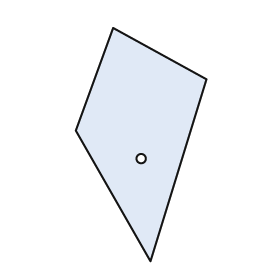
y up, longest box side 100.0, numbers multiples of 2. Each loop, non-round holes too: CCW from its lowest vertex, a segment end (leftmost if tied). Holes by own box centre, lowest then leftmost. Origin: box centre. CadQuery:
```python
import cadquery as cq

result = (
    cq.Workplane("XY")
    .moveTo(4.0, -50.0)
    .lineTo(28.0, 28.0)
    .lineTo(-12.0, 50.0)
    .lineTo(-28.0, 6.0)
    .close()
    .moveTo(0.0, -6.0)
    .circle(2.0)
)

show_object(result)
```